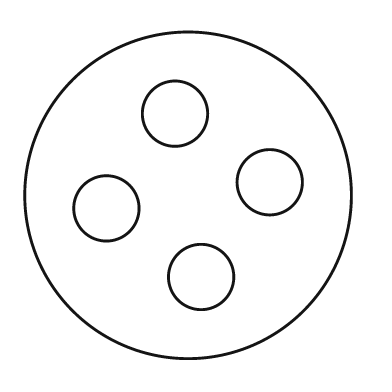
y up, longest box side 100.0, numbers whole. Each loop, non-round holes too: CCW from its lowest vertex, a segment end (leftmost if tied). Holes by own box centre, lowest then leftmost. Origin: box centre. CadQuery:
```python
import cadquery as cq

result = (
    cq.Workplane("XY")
    .moveTo(0.0, 0.0)
    .circle(50.0)
    .moveTo(4.0, -25.0)
    .circle(10.0)
    .moveTo(-25.0, -4.0)
    .circle(10.0)
    .moveTo(25.0, 4.0)
    .circle(10.0)
    .moveTo(-4.0, 25.0)
    .circle(10.0)
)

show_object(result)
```